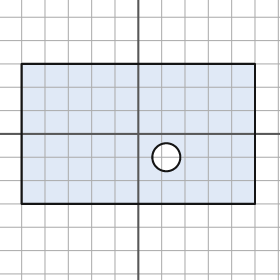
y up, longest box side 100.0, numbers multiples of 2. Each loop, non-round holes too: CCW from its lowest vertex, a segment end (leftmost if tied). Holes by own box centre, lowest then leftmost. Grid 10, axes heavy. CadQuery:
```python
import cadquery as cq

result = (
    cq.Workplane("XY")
    .moveTo(-50.0, -30.0)
    .lineTo(50.0, -30.0)
    .lineTo(50.0, 30.0)
    .lineTo(-50.0, 30.0)
    .close()
    .moveTo(12.0, -10.0)
    .circle(6.0)
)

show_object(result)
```